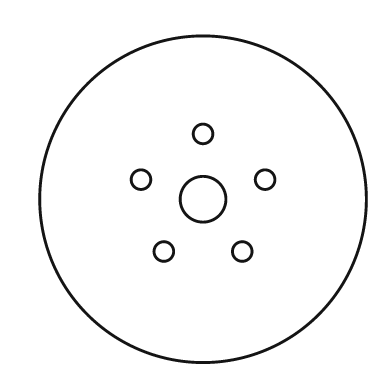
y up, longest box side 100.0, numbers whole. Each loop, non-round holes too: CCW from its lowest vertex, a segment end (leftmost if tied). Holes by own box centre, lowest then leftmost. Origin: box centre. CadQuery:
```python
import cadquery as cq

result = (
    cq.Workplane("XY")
    .moveTo(0.0, 0.0)
    .circle(50.0)
    .moveTo(-12.0, -16.0)
    .circle(3.0)
    .moveTo(12.0, -16.0)
    .circle(3.0)
    .moveTo(0.0, 0.0)
    .circle(7.0)
    .moveTo(-19.0, 6.0)
    .circle(3.0)
    .moveTo(19.0, 6.0)
    .circle(3.0)
    .moveTo(0.0, 20.0)
    .circle(3.0)
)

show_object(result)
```